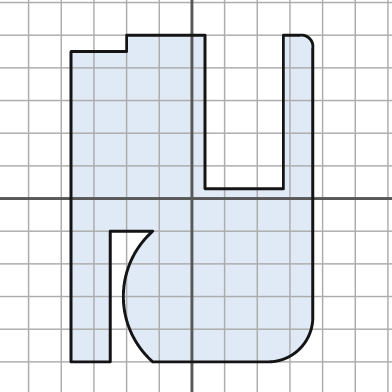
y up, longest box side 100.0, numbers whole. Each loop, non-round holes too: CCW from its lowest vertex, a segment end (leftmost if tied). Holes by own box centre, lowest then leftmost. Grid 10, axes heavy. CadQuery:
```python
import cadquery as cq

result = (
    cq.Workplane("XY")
    .moveTo(-37.0, -50.0)
    .lineTo(-25.0, -50.0)
    .lineTo(-25.0, -10.0)
    .lineTo(-12.0, -10.0)
    .threePointArc((-21.0, -30.0), (-12.0, -50.0))
    .lineTo(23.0, -50.0)
    .threePointArc((33.0, -46.0), (37.0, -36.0))
    .lineTo(37.0, 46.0)
    .threePointArc((36.0, 49.0), (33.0, 50.0))
    .lineTo(28.0, 50.0)
    .lineTo(28.0, 3.0)
    .lineTo(4.0, 3.0)
    .lineTo(4.0, 50.0)
    .lineTo(-20.0, 50.0)
    .lineTo(-20.0, 45.0)
    .lineTo(-37.0, 45.0)
    .close()
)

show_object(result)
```